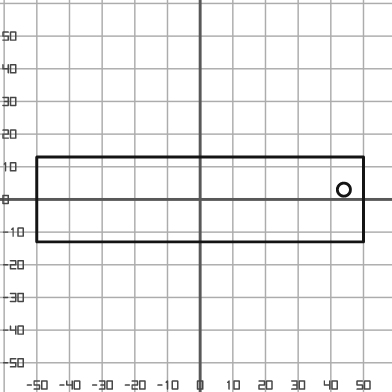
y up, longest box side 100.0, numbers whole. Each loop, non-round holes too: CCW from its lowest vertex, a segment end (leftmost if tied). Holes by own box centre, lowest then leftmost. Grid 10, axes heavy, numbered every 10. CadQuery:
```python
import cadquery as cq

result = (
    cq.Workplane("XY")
    .moveTo(-50.0, -13.0)
    .lineTo(50.0, -13.0)
    .lineTo(50.0, 13.0)
    .lineTo(-50.0, 13.0)
    .close()
    .moveTo(44.0, 3.0)
    .circle(2.0)
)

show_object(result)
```